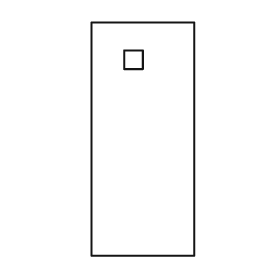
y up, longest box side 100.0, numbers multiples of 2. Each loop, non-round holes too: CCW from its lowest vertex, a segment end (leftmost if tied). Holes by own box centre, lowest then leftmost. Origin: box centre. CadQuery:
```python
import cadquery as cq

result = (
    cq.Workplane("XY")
    .moveTo(-22.0, -50.0)
    .lineTo(22.0, -50.0)
    .lineTo(22.0, 50.0)
    .lineTo(-22.0, 50.0)
    .close()
    .moveTo(-8.0, 30.0)
    .lineTo(0.0, 30.0)
    .lineTo(0.0, 38.0)
    .lineTo(-8.0, 38.0)
    .close()
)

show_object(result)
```